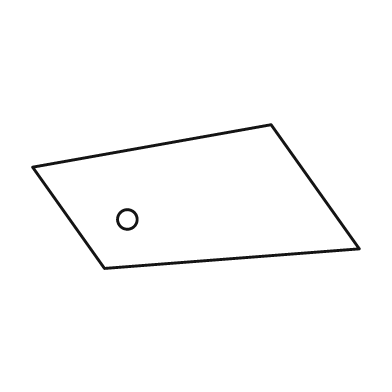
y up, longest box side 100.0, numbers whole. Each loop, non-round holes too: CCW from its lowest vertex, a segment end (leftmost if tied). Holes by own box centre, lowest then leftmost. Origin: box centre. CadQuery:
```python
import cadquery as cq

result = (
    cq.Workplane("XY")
    .moveTo(-28.0, -22.0)
    .lineTo(50.0, -16.0)
    .lineTo(23.0, 22.0)
    .lineTo(-50.0, 9.0)
    .close()
    .moveTo(-21.0, -7.0)
    .circle(3.0)
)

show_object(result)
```